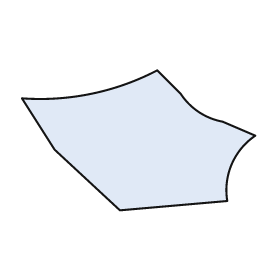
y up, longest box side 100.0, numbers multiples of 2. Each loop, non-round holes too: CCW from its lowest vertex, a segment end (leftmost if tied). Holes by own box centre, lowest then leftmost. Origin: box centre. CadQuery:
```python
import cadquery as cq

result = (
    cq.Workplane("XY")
    .moveTo(-8.0, -30.0)
    .lineTo(38.0, -26.0)
    .threePointArc((40.0, -10.0), (50.0, 2.0))
    .lineTo(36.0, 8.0)
    .threePointArc((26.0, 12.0), (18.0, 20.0))
    .lineTo(8.0, 30.0)
    .threePointArc((-20.0, 20.0), (-50.0, 18.0))
    .lineTo(-36.0, -4.0)
    .close()
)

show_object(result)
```